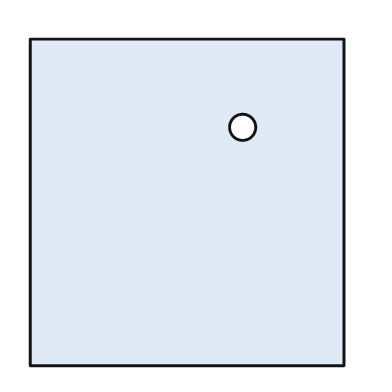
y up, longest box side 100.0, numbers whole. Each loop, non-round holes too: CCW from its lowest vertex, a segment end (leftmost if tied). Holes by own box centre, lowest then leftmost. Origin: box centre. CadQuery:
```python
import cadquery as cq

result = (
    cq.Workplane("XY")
    .moveTo(-48.0, -50.0)
    .lineTo(48.0, -50.0)
    .lineTo(48.0, 50.0)
    .lineTo(-48.0, 50.0)
    .close()
    .moveTo(17.0, 23.0)
    .circle(4.0)
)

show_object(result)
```